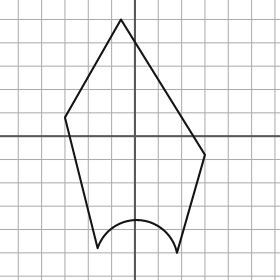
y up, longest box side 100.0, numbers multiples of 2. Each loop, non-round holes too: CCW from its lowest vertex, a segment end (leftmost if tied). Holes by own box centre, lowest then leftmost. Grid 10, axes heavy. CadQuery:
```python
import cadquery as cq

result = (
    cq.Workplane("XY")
    .moveTo(18.0, -50.0)
    .lineTo(30.0, -8.0)
    .lineTo(-6.0, 50.0)
    .lineTo(-30.0, 8.0)
    .lineTo(-16.0, -48.0)
    .threePointArc((2.0, -36.0), (18.0, -50.0))
    .close()
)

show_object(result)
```